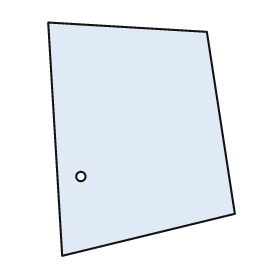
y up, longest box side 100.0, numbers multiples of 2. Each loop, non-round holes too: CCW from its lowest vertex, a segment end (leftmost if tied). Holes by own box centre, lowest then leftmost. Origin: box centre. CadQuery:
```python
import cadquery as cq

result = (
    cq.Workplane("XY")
    .moveTo(-34.0, -50.0)
    .lineTo(40.0, -32.0)
    .lineTo(28.0, 46.0)
    .lineTo(-40.0, 50.0)
    .close()
    .moveTo(-26.0, -16.0)
    .circle(2.0)
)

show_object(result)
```